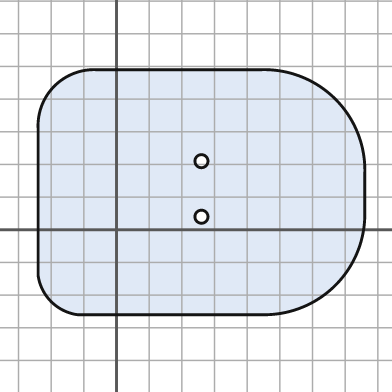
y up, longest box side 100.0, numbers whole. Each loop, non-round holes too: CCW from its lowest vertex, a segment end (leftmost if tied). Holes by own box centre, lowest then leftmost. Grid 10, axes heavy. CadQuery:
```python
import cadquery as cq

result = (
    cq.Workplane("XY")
    .moveTo(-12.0, -26.0)
    .lineTo(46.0, -26.0)
    .threePointArc((67.0, -17.0), (76.0, 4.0))
    .lineTo(76.0, 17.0)
    .threePointArc((67.0, 40.0), (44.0, 49.0))
    .lineTo(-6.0, 49.0)
    .threePointArc((-19.0, 44.0), (-24.0, 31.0))
    .lineTo(-24.0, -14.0)
    .threePointArc((-20.0, -22.0), (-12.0, -26.0))
    .close()
    .moveTo(26.0, 4.0)
    .circle(2.0)
    .moveTo(26.0, 21.0)
    .circle(2.0)
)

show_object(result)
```